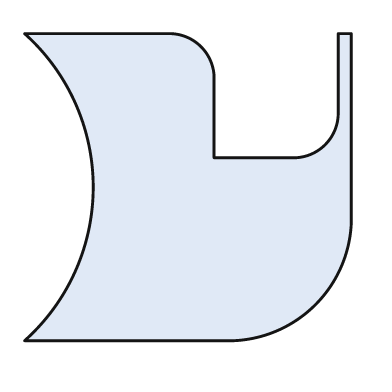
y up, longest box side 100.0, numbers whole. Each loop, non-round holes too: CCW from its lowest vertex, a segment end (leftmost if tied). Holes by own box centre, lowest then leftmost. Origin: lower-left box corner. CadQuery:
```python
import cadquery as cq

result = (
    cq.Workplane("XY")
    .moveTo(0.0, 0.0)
    .lineTo(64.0, 0.0)
    .threePointArc((89.0, 11.0), (100.0, 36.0))
    .lineTo(100.0, 94.0)
    .lineTo(96.0, 94.0)
    .lineTo(96.0, 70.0)
    .threePointArc((92.0, 60.0), (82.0, 56.0))
    .lineTo(58.0, 56.0)
    .lineTo(58.0, 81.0)
    .threePointArc((54.0, 90.0), (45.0, 94.0))
    .lineTo(0.0, 94.0)
    .threePointArc((21.0, 47.0), (0.0, 0.0))
    .close()
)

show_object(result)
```